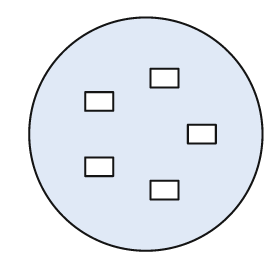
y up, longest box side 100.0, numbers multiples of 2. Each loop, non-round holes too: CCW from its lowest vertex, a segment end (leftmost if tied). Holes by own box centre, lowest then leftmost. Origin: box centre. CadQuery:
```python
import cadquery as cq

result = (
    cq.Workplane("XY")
    .moveTo(0.0, 0.0)
    .circle(50.0)
    .moveTo(2.0, -28.0)
    .lineTo(14.0, -28.0)
    .lineTo(14.0, -20.0)
    .lineTo(2.0, -20.0)
    .close()
    .moveTo(-26.0, -18.0)
    .lineTo(-14.0, -18.0)
    .lineTo(-14.0, -10.0)
    .lineTo(-26.0, -10.0)
    .close()
    .moveTo(18.0, -4.0)
    .lineTo(30.0, -4.0)
    .lineTo(30.0, 4.0)
    .lineTo(18.0, 4.0)
    .close()
    .moveTo(-26.0, 10.0)
    .lineTo(-14.0, 10.0)
    .lineTo(-14.0, 18.0)
    .lineTo(-26.0, 18.0)
    .close()
    .moveTo(2.0, 20.0)
    .lineTo(14.0, 20.0)
    .lineTo(14.0, 28.0)
    .lineTo(2.0, 28.0)
    .close()
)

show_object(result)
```